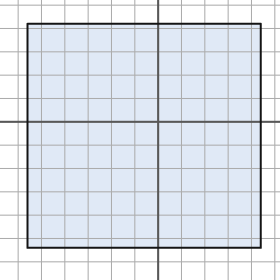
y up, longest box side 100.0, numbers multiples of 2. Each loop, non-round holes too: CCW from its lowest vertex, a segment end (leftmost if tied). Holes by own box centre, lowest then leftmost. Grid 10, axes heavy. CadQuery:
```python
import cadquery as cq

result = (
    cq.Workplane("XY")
    .moveTo(-56.0, -54.0)
    .lineTo(44.0, -54.0)
    .lineTo(44.0, 42.0)
    .lineTo(-56.0, 42.0)
    .close()
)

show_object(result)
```